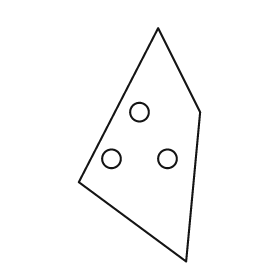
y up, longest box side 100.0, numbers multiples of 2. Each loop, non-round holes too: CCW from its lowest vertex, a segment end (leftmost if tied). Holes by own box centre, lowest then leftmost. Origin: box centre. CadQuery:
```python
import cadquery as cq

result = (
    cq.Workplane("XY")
    .moveTo(20.0, -50.0)
    .lineTo(26.0, 14.0)
    .lineTo(8.0, 50.0)
    .lineTo(-26.0, -16.0)
    .close()
    .moveTo(-12.0, -6.0)
    .circle(4.0)
    .moveTo(12.0, -6.0)
    .circle(4.0)
    .moveTo(0.0, 14.0)
    .circle(4.0)
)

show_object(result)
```